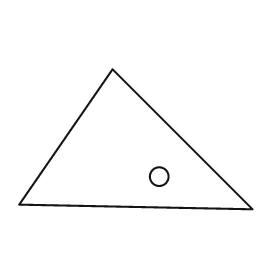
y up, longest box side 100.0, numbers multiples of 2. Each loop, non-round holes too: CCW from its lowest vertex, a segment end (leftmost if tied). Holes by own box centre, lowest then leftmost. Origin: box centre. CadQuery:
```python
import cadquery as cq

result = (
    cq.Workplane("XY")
    .moveTo(50.0, -30.0)
    .lineTo(-10.0, 30.0)
    .lineTo(-50.0, -28.0)
    .close()
    .moveTo(10.0, -16.0)
    .circle(4.0)
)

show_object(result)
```